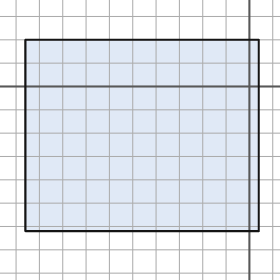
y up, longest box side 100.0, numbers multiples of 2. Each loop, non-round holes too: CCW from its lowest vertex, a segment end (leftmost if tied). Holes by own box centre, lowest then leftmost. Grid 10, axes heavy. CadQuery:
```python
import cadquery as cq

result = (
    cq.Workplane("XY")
    .moveTo(-96.0, -62.0)
    .lineTo(4.0, -62.0)
    .lineTo(4.0, 20.0)
    .lineTo(-96.0, 20.0)
    .close()
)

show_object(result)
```